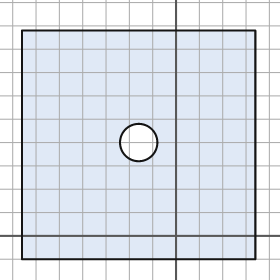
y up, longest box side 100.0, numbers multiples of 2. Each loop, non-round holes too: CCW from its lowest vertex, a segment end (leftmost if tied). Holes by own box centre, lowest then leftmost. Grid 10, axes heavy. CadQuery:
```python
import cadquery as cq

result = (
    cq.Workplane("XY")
    .moveTo(-66.0, -10.0)
    .lineTo(34.0, -10.0)
    .lineTo(34.0, 88.0)
    .lineTo(-66.0, 88.0)
    .close()
    .moveTo(-16.0, 40.0)
    .circle(8.0)
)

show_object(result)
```